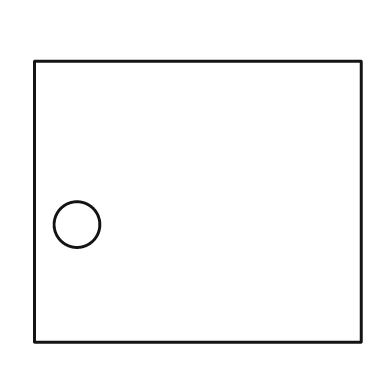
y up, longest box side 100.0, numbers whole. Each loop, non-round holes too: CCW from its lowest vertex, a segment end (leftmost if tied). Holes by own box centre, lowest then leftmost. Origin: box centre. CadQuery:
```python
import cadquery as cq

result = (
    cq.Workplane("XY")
    .moveTo(-50.0, -43.0)
    .lineTo(50.0, -43.0)
    .lineTo(50.0, 43.0)
    .lineTo(-50.0, 43.0)
    .close()
    .moveTo(-37.0, -7.0)
    .circle(7.0)
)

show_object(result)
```